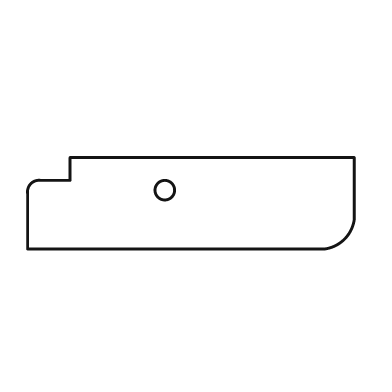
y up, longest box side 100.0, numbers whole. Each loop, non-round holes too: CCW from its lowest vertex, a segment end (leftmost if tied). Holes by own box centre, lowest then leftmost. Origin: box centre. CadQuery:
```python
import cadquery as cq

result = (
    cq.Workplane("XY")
    .moveTo(-50.0, -14.0)
    .lineTo(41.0, -14.0)
    .threePointArc((47.0, -11.0), (50.0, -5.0))
    .lineTo(50.0, 14.0)
    .lineTo(-37.0, 14.0)
    .lineTo(-37.0, 7.0)
    .lineTo(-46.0, 7.0)
    .threePointArc((-49.0, 6.0), (-50.0, 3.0))
    .close()
    .moveTo(-8.0, 4.0)
    .circle(3.0)
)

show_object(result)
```